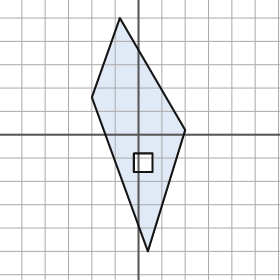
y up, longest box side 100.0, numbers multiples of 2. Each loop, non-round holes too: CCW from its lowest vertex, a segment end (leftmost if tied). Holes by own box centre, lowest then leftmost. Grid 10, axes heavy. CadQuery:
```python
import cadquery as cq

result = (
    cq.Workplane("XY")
    .moveTo(4.0, -50.0)
    .lineTo(20.0, 2.0)
    .lineTo(-8.0, 50.0)
    .lineTo(-20.0, 16.0)
    .close()
    .moveTo(-2.0, -16.0)
    .lineTo(6.0, -16.0)
    .lineTo(6.0, -8.0)
    .lineTo(-2.0, -8.0)
    .close()
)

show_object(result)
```